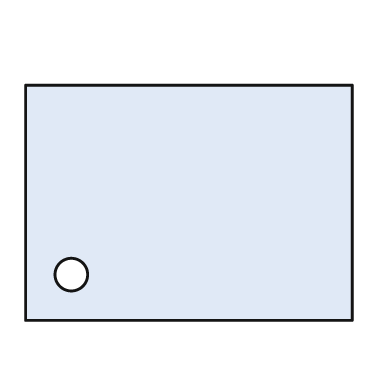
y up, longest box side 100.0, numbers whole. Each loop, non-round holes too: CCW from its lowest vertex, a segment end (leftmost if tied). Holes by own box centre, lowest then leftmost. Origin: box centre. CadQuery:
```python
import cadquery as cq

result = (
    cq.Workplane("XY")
    .moveTo(-50.0, -36.0)
    .lineTo(50.0, -36.0)
    .lineTo(50.0, 36.0)
    .lineTo(-50.0, 36.0)
    .close()
    .moveTo(-36.0, -22.0)
    .circle(5.0)
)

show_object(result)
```